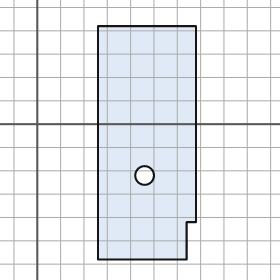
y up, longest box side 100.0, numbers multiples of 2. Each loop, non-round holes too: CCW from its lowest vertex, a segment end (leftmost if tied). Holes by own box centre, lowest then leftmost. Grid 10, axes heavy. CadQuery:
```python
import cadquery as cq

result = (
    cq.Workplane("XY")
    .moveTo(26.0, -58.0)
    .lineTo(64.0, -58.0)
    .lineTo(64.0, -42.0)
    .lineTo(68.0, -42.0)
    .lineTo(68.0, 42.0)
    .lineTo(26.0, 42.0)
    .close()
    .moveTo(46.0, -22.0)
    .circle(4.0)
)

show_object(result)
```